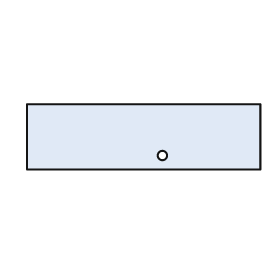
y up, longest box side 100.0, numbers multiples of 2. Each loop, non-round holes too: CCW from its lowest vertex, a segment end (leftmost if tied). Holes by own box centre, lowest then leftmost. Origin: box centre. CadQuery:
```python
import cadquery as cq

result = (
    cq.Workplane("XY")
    .moveTo(-50.0, -14.0)
    .lineTo(50.0, -14.0)
    .lineTo(50.0, 14.0)
    .lineTo(-50.0, 14.0)
    .close()
    .moveTo(8.0, -8.0)
    .circle(2.0)
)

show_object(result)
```